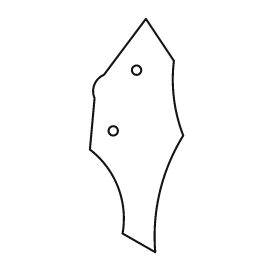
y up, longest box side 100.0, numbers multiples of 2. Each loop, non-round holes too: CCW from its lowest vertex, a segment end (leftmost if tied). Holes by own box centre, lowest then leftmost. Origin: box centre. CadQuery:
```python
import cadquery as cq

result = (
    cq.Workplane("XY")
    .moveTo(8.0, -50.0)
    .threePointArc((10.0, -24.0), (20.0, 0.0))
    .threePointArc((16.0, 16.0), (16.0, 32.0))
    .lineTo(4.0, 50.0)
    .lineTo(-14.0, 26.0)
    .threePointArc((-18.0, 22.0), (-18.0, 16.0))
    .lineTo(-20.0, -6.0)
    .threePointArc((-8.0, -22.0), (-6.0, -42.0))
    .close()
    .moveTo(-10.0, 2.0)
    .circle(2.0)
    .moveTo(0.0, 28.0)
    .circle(2.0)
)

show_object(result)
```